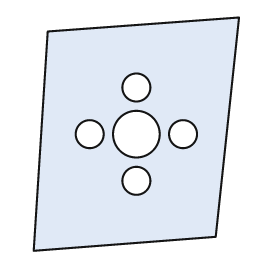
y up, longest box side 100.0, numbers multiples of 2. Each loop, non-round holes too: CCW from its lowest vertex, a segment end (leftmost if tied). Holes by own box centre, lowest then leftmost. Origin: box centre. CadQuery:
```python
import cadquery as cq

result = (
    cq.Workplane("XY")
    .moveTo(-44.0, -50.0)
    .lineTo(34.0, -44.0)
    .lineTo(44.0, 50.0)
    .lineTo(-38.0, 44.0)
    .close()
    .moveTo(0.0, -20.0)
    .circle(6.0)
    .moveTo(-20.0, 0.0)
    .circle(6.0)
    .moveTo(0.0, 0.0)
    .circle(10.0)
    .moveTo(20.0, 0.0)
    .circle(6.0)
    .moveTo(0.0, 20.0)
    .circle(6.0)
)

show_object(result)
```